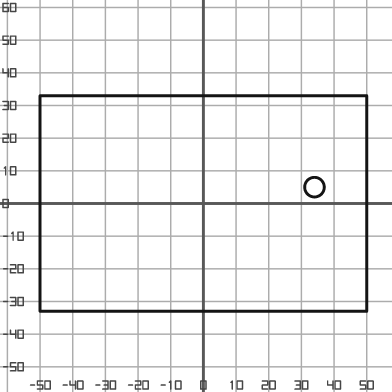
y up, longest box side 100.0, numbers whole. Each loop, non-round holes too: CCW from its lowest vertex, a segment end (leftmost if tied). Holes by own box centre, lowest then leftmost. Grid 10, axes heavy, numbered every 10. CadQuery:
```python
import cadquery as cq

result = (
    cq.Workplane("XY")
    .moveTo(-50.0, -33.0)
    .lineTo(50.0, -33.0)
    .lineTo(50.0, 33.0)
    .lineTo(-50.0, 33.0)
    .close()
    .moveTo(34.0, 5.0)
    .circle(3.0)
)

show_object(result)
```